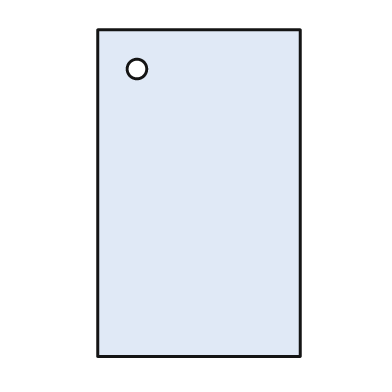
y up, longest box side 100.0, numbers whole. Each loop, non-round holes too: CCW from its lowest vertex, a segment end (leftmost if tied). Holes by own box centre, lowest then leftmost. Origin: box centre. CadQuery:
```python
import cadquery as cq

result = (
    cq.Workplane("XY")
    .moveTo(-31.0, -50.0)
    .lineTo(31.0, -50.0)
    .lineTo(31.0, 50.0)
    .lineTo(-31.0, 50.0)
    .close()
    .moveTo(-19.0, 38.0)
    .circle(3.0)
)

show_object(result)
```